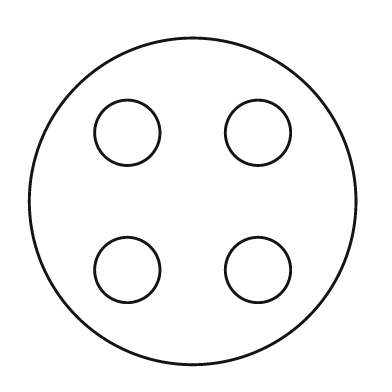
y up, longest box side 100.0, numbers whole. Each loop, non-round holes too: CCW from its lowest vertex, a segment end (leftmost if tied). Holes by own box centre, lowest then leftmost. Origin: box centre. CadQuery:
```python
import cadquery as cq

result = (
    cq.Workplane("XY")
    .moveTo(0.0, 0.0)
    .circle(50.0)
    .moveTo(-20.0, -21.0)
    .circle(10.0)
    .moveTo(20.0, -21.0)
    .circle(10.0)
    .moveTo(-20.0, 21.0)
    .circle(10.0)
    .moveTo(20.0, 21.0)
    .circle(10.0)
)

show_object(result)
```